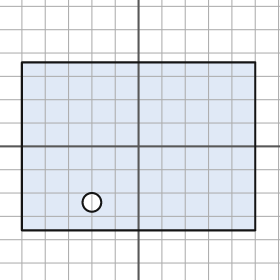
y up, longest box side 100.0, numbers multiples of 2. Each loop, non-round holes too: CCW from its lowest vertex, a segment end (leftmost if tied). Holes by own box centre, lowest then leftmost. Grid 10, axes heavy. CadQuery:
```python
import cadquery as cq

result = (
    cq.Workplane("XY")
    .moveTo(-50.0, -36.0)
    .lineTo(50.0, -36.0)
    .lineTo(50.0, 36.0)
    .lineTo(-50.0, 36.0)
    .close()
    .moveTo(-20.0, -24.0)
    .circle(4.0)
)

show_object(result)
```